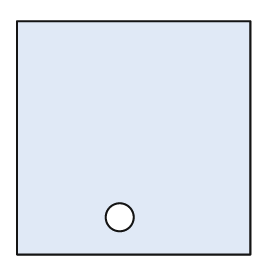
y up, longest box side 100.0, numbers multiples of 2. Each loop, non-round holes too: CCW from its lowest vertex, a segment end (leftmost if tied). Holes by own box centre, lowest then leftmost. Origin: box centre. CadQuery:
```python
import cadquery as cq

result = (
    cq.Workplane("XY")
    .moveTo(-50.0, -50.0)
    .lineTo(50.0, -50.0)
    .lineTo(50.0, 50.0)
    .lineTo(-50.0, 50.0)
    .close()
    .moveTo(-6.0, -34.0)
    .circle(6.0)
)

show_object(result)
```